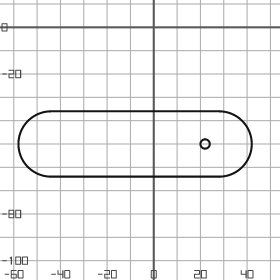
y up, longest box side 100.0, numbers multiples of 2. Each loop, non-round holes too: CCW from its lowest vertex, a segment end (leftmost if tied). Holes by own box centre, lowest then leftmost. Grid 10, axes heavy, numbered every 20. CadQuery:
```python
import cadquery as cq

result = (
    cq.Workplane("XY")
    .moveTo(-44.0, -64.0)
    .lineTo(28.0, -64.0)
    .threePointArc((42.0, -50.0), (28.0, -36.0))
    .lineTo(-44.0, -36.0)
    .threePointArc((-58.0, -50.0), (-44.0, -64.0))
    .close()
    .moveTo(22.0, -50.0)
    .circle(2.0)
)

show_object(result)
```